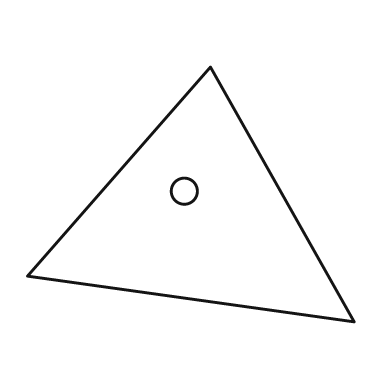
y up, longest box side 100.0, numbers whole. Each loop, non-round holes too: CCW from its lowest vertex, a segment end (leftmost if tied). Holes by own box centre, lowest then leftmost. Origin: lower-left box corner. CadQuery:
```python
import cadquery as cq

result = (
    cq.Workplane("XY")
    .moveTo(100.0, 0.0)
    .lineTo(56.0, 78.0)
    .lineTo(0.0, 14.0)
    .close()
    .moveTo(48.0, 40.0)
    .circle(4.0)
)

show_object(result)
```